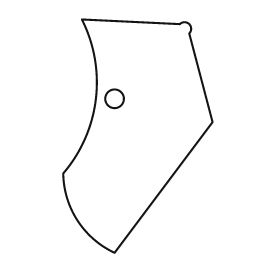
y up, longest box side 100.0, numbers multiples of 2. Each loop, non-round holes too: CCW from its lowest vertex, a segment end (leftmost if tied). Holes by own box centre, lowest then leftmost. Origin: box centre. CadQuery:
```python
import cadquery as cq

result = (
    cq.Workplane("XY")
    .moveTo(-10.0, -50.0)
    .lineTo(32.0, 6.0)
    .lineTo(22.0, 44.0)
    .threePointArc((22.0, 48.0), (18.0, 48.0))
    .lineTo(-24.0, 50.0)
    .threePointArc((-18.0, 16.0), (-32.0, -16.0))
    .threePointArc((-26.0, -36.0), (-10.0, -50.0))
    .close()
    .moveTo(-10.0, 16.0)
    .circle(4.0)
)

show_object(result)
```